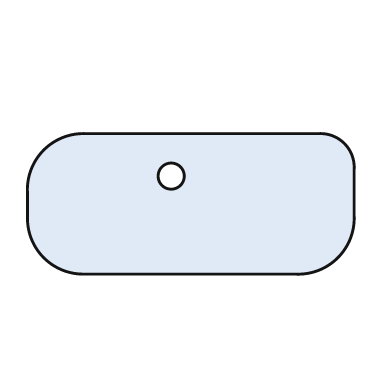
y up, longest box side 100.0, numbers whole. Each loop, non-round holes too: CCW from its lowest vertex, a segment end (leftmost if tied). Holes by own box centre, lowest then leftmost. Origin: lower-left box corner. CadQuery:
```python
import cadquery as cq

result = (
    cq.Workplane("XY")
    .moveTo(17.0, 0.0)
    .lineTo(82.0, 0.0)
    .threePointArc((95.0, 5.0), (100.0, 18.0))
    .lineTo(100.0, 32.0)
    .threePointArc((97.0, 40.0), (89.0, 43.0))
    .lineTo(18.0, 43.0)
    .threePointArc((5.0, 38.0), (0.0, 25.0))
    .lineTo(0.0, 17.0)
    .threePointArc((5.0, 5.0), (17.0, 0.0))
    .close()
    .moveTo(44.0, 30.0)
    .circle(4.0)
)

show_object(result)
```